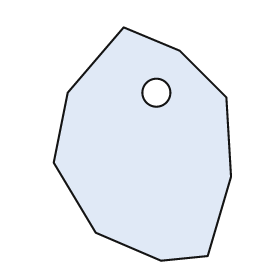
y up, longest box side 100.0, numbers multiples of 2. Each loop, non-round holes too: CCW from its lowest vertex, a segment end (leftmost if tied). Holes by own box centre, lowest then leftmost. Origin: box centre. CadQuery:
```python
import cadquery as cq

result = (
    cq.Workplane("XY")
    .moveTo(8.0, -50.0)
    .lineTo(28.0, -48.0)
    .lineTo(38.0, -14.0)
    .lineTo(36.0, 20.0)
    .lineTo(16.0, 40.0)
    .lineTo(-8.0, 50.0)
    .lineTo(-32.0, 22.0)
    .lineTo(-38.0, -8.0)
    .lineTo(-20.0, -38.0)
    .close()
    .moveTo(6.0, 22.0)
    .circle(6.0)
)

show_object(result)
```